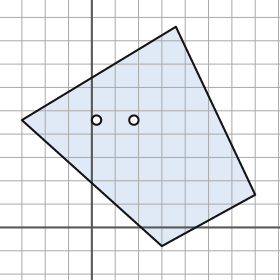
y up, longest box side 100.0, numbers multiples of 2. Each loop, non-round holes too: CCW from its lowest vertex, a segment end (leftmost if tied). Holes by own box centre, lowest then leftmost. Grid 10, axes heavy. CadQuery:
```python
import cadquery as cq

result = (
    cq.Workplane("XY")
    .moveTo(30.0, -8.0)
    .lineTo(70.0, 14.0)
    .lineTo(36.0, 86.0)
    .lineTo(-30.0, 46.0)
    .close()
    .moveTo(2.0, 46.0)
    .circle(2.0)
    .moveTo(18.0, 46.0)
    .circle(2.0)
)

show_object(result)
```